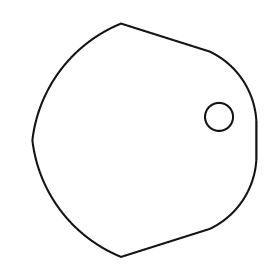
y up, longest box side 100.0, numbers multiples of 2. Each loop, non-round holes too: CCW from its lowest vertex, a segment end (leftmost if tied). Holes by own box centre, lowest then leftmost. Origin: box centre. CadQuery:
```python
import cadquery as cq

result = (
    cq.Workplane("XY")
    .moveTo(-10.0, -50.0)
    .lineTo(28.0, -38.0)
    .threePointArc((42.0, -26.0), (48.0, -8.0))
    .lineTo(48.0, 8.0)
    .threePointArc((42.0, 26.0), (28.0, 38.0))
    .lineTo(-10.0, 50.0)
    .threePointArc((-36.0, 30.0), (-48.0, 0.0))
    .threePointArc((-36.0, -30.0), (-10.0, -50.0))
    .close()
    .moveTo(32.0, 10.0)
    .circle(6.0)
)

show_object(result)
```